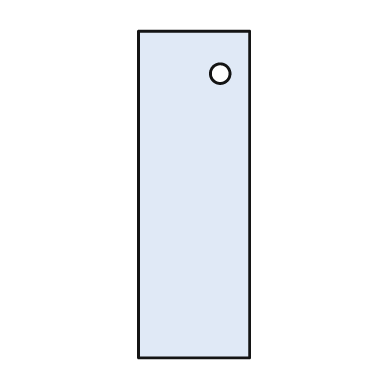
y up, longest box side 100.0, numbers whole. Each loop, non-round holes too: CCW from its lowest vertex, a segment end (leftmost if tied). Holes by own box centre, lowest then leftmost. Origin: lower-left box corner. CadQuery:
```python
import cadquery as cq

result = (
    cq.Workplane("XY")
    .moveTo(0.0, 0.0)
    .lineTo(34.0, 0.0)
    .lineTo(34.0, 100.0)
    .lineTo(0.0, 100.0)
    .close()
    .moveTo(25.0, 87.0)
    .circle(3.0)
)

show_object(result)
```